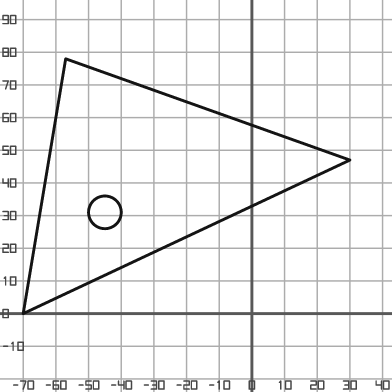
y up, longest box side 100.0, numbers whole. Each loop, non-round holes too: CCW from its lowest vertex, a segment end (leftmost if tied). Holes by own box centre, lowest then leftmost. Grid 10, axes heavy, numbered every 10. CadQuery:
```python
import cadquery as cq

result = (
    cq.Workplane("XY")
    .moveTo(-70.0, 0.0)
    .lineTo(30.0, 47.0)
    .lineTo(-57.0, 78.0)
    .close()
    .moveTo(-45.0, 31.0)
    .circle(5.0)
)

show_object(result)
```